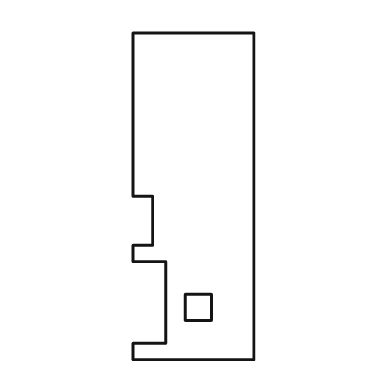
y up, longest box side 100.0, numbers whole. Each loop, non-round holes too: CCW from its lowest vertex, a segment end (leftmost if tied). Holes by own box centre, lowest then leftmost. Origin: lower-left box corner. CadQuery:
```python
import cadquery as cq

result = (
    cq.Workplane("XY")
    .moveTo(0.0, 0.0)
    .lineTo(37.0, 0.0)
    .lineTo(37.0, 100.0)
    .lineTo(0.0, 100.0)
    .lineTo(0.0, 50.0)
    .lineTo(6.0, 50.0)
    .lineTo(6.0, 35.0)
    .lineTo(0.0, 35.0)
    .lineTo(0.0, 30.0)
    .lineTo(10.0, 30.0)
    .lineTo(10.0, 5.0)
    .lineTo(0.0, 5.0)
    .close()
    .moveTo(16.0, 12.0)
    .lineTo(24.0, 12.0)
    .lineTo(24.0, 20.0)
    .lineTo(16.0, 20.0)
    .close()
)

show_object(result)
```